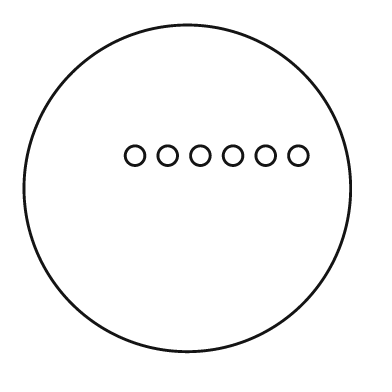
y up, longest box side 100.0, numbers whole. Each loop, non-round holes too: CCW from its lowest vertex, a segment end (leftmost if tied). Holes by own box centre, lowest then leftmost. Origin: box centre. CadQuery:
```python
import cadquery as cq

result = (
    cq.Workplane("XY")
    .moveTo(0.0, 0.0)
    .circle(50.0)
    .moveTo(-16.0, 10.0)
    .circle(3.0)
    .moveTo(-6.0, 10.0)
    .circle(3.0)
    .moveTo(4.0, 10.0)
    .circle(3.0)
    .moveTo(14.0, 10.0)
    .circle(3.0)
    .moveTo(24.0, 10.0)
    .circle(3.0)
    .moveTo(34.0, 10.0)
    .circle(3.0)
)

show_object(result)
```